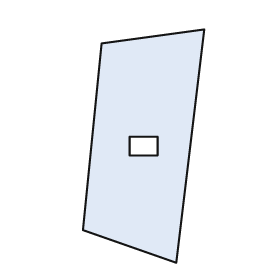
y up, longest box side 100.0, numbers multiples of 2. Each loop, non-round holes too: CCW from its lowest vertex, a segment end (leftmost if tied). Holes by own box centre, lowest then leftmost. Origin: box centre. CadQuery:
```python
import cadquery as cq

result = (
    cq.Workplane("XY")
    .moveTo(14.0, -50.0)
    .lineTo(26.0, 50.0)
    .lineTo(-18.0, 44.0)
    .lineTo(-26.0, -36.0)
    .close()
    .moveTo(-6.0, -4.0)
    .lineTo(6.0, -4.0)
    .lineTo(6.0, 4.0)
    .lineTo(-6.0, 4.0)
    .close()
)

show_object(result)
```